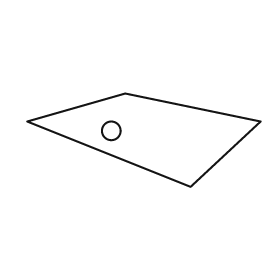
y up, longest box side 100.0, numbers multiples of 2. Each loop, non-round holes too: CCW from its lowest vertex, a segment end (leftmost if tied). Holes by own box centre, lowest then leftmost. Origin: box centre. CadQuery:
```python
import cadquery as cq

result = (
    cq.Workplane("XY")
    .moveTo(20.0, -20.0)
    .lineTo(50.0, 8.0)
    .lineTo(-8.0, 20.0)
    .lineTo(-50.0, 8.0)
    .close()
    .moveTo(-14.0, 4.0)
    .circle(4.0)
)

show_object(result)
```